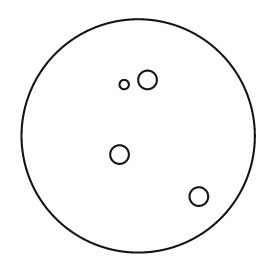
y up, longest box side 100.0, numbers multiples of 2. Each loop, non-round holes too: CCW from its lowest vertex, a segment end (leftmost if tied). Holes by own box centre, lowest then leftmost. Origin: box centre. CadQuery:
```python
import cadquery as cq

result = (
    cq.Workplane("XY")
    .moveTo(0.0, 0.0)
    .circle(50.0)
    .moveTo(26.0, -26.0)
    .circle(4.0)
    .moveTo(-8.0, -8.0)
    .circle(4.0)
    .moveTo(-6.0, 22.0)
    .circle(2.0)
    .moveTo(4.0, 24.0)
    .circle(4.0)
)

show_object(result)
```